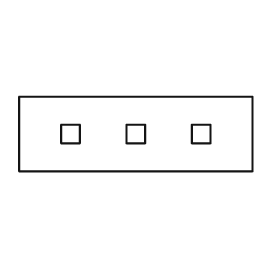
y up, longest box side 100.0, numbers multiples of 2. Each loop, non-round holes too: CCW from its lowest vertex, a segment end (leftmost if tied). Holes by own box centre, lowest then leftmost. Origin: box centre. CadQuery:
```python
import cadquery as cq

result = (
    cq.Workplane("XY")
    .moveTo(-50.0, -16.0)
    .lineTo(50.0, -16.0)
    .lineTo(50.0, 16.0)
    .lineTo(-50.0, 16.0)
    .close()
    .moveTo(-32.0, -4.0)
    .lineTo(-24.0, -4.0)
    .lineTo(-24.0, 4.0)
    .lineTo(-32.0, 4.0)
    .close()
    .moveTo(-4.0, -4.0)
    .lineTo(4.0, -4.0)
    .lineTo(4.0, 4.0)
    .lineTo(-4.0, 4.0)
    .close()
    .moveTo(24.0, -4.0)
    .lineTo(32.0, -4.0)
    .lineTo(32.0, 4.0)
    .lineTo(24.0, 4.0)
    .close()
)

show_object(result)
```